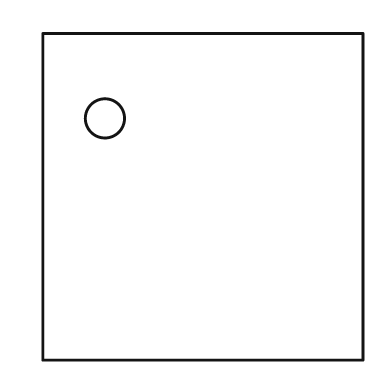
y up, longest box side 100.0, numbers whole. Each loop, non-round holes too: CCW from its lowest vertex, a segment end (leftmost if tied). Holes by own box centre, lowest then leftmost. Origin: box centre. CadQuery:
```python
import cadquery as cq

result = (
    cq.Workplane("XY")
    .moveTo(-49.0, -50.0)
    .lineTo(49.0, -50.0)
    .lineTo(49.0, 50.0)
    .lineTo(-49.0, 50.0)
    .close()
    .moveTo(-30.0, 24.0)
    .circle(6.0)
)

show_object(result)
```